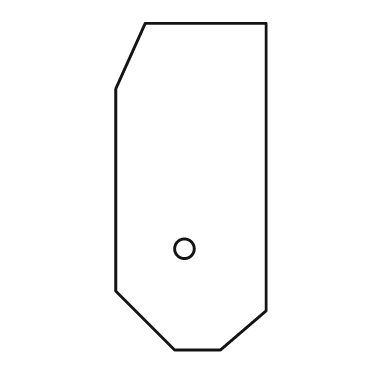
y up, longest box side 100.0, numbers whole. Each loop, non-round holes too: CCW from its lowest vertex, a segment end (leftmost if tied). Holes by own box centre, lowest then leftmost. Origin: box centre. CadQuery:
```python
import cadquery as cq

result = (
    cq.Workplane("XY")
    .moveTo(-5.0, -50.0)
    .lineTo(9.0, -50.0)
    .lineTo(23.0, -38.0)
    .lineTo(23.0, 50.0)
    .lineTo(-14.0, 50.0)
    .lineTo(-23.0, 30.0)
    .lineTo(-23.0, -32.0)
    .close()
    .moveTo(-2.0, -19.0)
    .circle(3.0)
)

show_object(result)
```